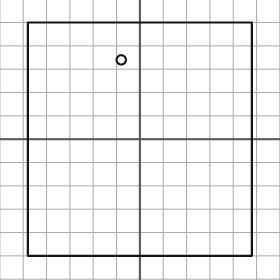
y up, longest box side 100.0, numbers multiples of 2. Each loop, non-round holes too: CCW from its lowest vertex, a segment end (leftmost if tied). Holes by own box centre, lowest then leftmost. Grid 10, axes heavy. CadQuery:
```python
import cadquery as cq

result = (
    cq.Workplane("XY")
    .moveTo(-48.0, -50.0)
    .lineTo(48.0, -50.0)
    .lineTo(48.0, 50.0)
    .lineTo(-48.0, 50.0)
    .close()
    .moveTo(-8.0, 34.0)
    .circle(2.0)
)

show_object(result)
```